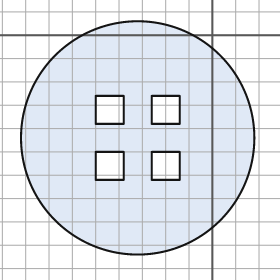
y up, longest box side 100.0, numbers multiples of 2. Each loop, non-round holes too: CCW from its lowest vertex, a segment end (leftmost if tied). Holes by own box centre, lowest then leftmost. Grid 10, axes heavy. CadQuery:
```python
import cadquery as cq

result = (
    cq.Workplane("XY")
    .moveTo(-32.0, -44.0)
    .circle(50.0)
    .moveTo(-50.0, -62.0)
    .lineTo(-38.0, -62.0)
    .lineTo(-38.0, -50.0)
    .lineTo(-50.0, -50.0)
    .close()
    .moveTo(-26.0, -62.0)
    .lineTo(-14.0, -62.0)
    .lineTo(-14.0, -50.0)
    .lineTo(-26.0, -50.0)
    .close()
    .moveTo(-50.0, -38.0)
    .lineTo(-38.0, -38.0)
    .lineTo(-38.0, -26.0)
    .lineTo(-50.0, -26.0)
    .close()
    .moveTo(-26.0, -38.0)
    .lineTo(-14.0, -38.0)
    .lineTo(-14.0, -26.0)
    .lineTo(-26.0, -26.0)
    .close()
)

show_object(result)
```